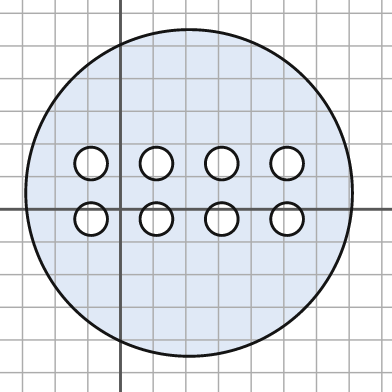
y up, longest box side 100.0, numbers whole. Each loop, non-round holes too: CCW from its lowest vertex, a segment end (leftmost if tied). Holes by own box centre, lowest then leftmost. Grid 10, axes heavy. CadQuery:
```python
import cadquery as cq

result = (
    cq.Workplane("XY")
    .moveTo(21.0, 5.0)
    .circle(50.0)
    .moveTo(-9.0, -3.0)
    .circle(5.0)
    .moveTo(11.0, -3.0)
    .circle(5.0)
    .moveTo(31.0, -3.0)
    .circle(5.0)
    .moveTo(51.0, -3.0)
    .circle(5.0)
    .moveTo(-9.0, 14.0)
    .circle(5.0)
    .moveTo(11.0, 14.0)
    .circle(5.0)
    .moveTo(31.0, 14.0)
    .circle(5.0)
    .moveTo(51.0, 14.0)
    .circle(5.0)
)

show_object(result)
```